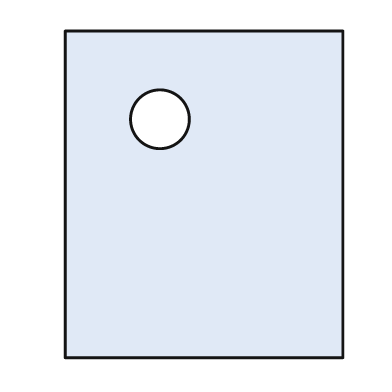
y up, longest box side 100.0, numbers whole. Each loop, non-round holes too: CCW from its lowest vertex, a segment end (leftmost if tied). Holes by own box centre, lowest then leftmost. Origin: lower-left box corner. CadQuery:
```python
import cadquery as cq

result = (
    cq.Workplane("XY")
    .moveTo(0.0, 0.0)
    .lineTo(85.0, 0.0)
    .lineTo(85.0, 100.0)
    .lineTo(0.0, 100.0)
    .close()
    .moveTo(29.0, 73.0)
    .circle(9.0)
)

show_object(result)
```